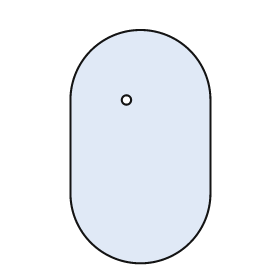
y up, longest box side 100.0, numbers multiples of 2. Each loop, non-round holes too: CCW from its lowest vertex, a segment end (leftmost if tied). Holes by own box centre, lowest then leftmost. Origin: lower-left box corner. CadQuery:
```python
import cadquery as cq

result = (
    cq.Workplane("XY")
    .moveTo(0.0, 30.0)
    .threePointArc((30.0, 0.0), (60.0, 30.0))
    .lineTo(60.0, 70.0)
    .threePointArc((30.0, 100.0), (0.0, 70.0))
    .close()
    .moveTo(24.0, 70.0)
    .circle(2.0)
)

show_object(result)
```